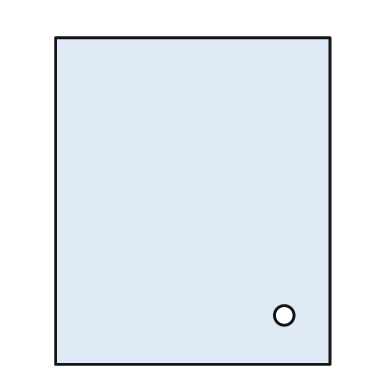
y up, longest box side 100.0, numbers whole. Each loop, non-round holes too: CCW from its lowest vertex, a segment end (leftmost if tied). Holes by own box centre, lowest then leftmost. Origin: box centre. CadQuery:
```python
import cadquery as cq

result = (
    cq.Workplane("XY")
    .moveTo(-42.0, -50.0)
    .lineTo(42.0, -50.0)
    .lineTo(42.0, 50.0)
    .lineTo(-42.0, 50.0)
    .close()
    .moveTo(28.0, -35.0)
    .circle(3.0)
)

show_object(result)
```